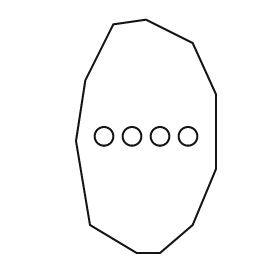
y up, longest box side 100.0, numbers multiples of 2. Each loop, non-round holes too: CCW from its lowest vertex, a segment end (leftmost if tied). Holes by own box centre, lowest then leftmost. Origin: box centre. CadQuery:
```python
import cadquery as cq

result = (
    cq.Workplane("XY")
    .moveTo(-4.0, -50.0)
    .lineTo(6.0, -50.0)
    .lineTo(20.0, -38.0)
    .lineTo(30.0, -14.0)
    .lineTo(30.0, 18.0)
    .lineTo(20.0, 40.0)
    .lineTo(0.0, 50.0)
    .lineTo(-14.0, 48.0)
    .lineTo(-26.0, 24.0)
    .lineTo(-30.0, -2.0)
    .lineTo(-24.0, -38.0)
    .close()
    .moveTo(-18.0, 0.0)
    .circle(4.0)
    .moveTo(-6.0, 0.0)
    .circle(4.0)
    .moveTo(6.0, 0.0)
    .circle(4.0)
    .moveTo(18.0, 0.0)
    .circle(4.0)
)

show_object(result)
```